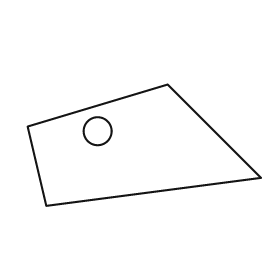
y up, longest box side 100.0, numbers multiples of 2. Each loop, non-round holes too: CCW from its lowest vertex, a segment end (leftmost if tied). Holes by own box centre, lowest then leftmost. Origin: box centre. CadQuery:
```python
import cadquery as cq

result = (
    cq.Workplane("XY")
    .moveTo(-42.0, -26.0)
    .lineTo(50.0, -14.0)
    .lineTo(10.0, 26.0)
    .lineTo(-50.0, 8.0)
    .close()
    .moveTo(-20.0, 6.0)
    .circle(6.0)
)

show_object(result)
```